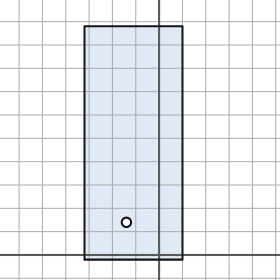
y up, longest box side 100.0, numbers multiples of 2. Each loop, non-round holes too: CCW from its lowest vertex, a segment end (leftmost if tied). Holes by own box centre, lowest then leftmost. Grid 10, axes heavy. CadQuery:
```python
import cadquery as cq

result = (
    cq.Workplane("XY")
    .moveTo(-32.0, -2.0)
    .lineTo(10.0, -2.0)
    .lineTo(10.0, 98.0)
    .lineTo(-32.0, 98.0)
    .close()
    .moveTo(-14.0, 14.0)
    .circle(2.0)
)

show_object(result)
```